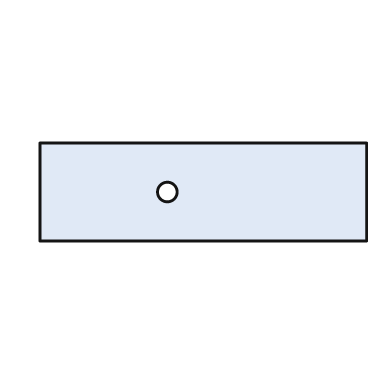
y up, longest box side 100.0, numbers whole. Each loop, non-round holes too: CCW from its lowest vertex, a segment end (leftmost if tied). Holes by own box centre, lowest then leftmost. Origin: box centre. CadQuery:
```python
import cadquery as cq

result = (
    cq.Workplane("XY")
    .moveTo(-50.0, -15.0)
    .lineTo(50.0, -15.0)
    .lineTo(50.0, 15.0)
    .lineTo(-50.0, 15.0)
    .close()
    .moveTo(-11.0, 0.0)
    .circle(3.0)
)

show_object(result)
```